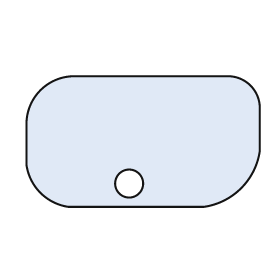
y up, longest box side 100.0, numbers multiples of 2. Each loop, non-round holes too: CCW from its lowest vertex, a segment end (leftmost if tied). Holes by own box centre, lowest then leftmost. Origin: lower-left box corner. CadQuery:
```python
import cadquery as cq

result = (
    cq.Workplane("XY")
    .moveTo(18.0, 0.0)
    .lineTo(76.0, 0.0)
    .threePointArc((92.0, 8.0), (100.0, 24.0))
    .lineTo(100.0, 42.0)
    .threePointArc((96.0, 52.0), (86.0, 56.0))
    .lineTo(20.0, 56.0)
    .threePointArc((6.0, 50.0), (0.0, 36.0))
    .lineTo(0.0, 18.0)
    .threePointArc((6.0, 6.0), (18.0, 0.0))
    .close()
    .moveTo(44.0, 10.0)
    .circle(6.0)
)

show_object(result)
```